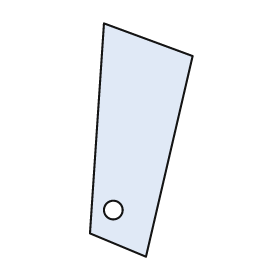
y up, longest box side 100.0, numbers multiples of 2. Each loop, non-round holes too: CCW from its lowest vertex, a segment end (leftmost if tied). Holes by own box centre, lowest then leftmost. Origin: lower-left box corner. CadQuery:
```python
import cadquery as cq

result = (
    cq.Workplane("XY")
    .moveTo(24.0, 0.0)
    .lineTo(44.0, 86.0)
    .lineTo(6.0, 100.0)
    .lineTo(0.0, 10.0)
    .close()
    .moveTo(10.0, 20.0)
    .circle(4.0)
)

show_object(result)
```